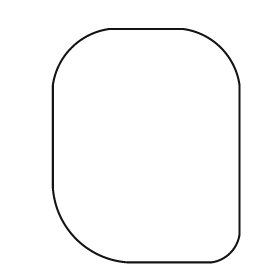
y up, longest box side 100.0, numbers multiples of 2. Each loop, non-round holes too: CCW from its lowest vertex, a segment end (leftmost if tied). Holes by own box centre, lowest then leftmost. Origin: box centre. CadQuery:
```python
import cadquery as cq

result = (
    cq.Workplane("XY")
    .moveTo(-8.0, -50.0)
    .lineTo(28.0, -50.0)
    .threePointArc((36.0, -46.0), (40.0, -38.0))
    .lineTo(40.0, 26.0)
    .threePointArc((32.0, 42.0), (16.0, 50.0))
    .lineTo(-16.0, 50.0)
    .threePointArc((-32.0, 42.0), (-40.0, 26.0))
    .lineTo(-40.0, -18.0)
    .threePointArc((-30.0, -40.0), (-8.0, -50.0))
    .close()
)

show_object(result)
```